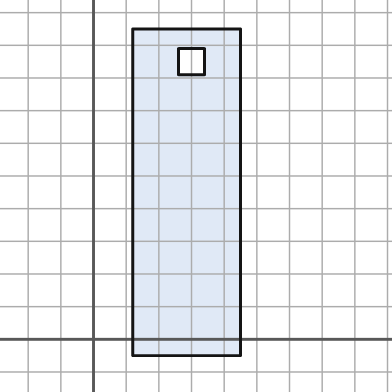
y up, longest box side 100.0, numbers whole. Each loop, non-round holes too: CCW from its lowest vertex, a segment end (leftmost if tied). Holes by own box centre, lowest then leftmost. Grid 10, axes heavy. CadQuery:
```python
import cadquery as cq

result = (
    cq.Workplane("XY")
    .moveTo(12.0, -5.0)
    .lineTo(45.0, -5.0)
    .lineTo(45.0, 95.0)
    .lineTo(12.0, 95.0)
    .close()
    .moveTo(26.0, 81.0)
    .lineTo(34.0, 81.0)
    .lineTo(34.0, 89.0)
    .lineTo(26.0, 89.0)
    .close()
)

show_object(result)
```